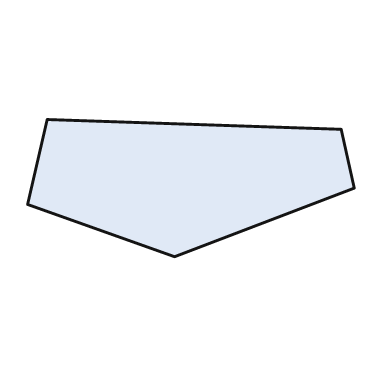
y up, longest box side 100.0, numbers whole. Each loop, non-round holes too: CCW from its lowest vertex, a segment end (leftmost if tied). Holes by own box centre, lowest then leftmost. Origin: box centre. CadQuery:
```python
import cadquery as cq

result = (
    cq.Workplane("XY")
    .moveTo(-5.0, -21.0)
    .lineTo(50.0, 0.0)
    .lineTo(46.0, 18.0)
    .lineTo(-44.0, 21.0)
    .lineTo(-50.0, -5.0)
    .close()
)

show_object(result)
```